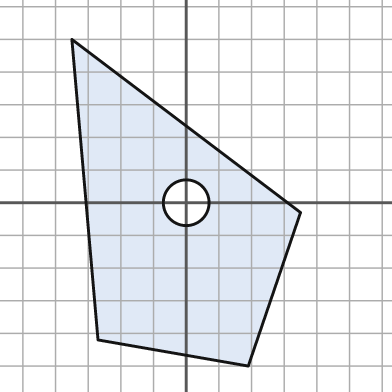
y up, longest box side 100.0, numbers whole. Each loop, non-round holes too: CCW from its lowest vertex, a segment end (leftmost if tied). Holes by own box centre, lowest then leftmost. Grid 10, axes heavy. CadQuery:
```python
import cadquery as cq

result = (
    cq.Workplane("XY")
    .moveTo(19.0, -50.0)
    .lineTo(35.0, -3.0)
    .lineTo(-35.0, 50.0)
    .lineTo(-27.0, -42.0)
    .close()
    .moveTo(0.0, 0.0)
    .circle(7.0)
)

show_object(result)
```